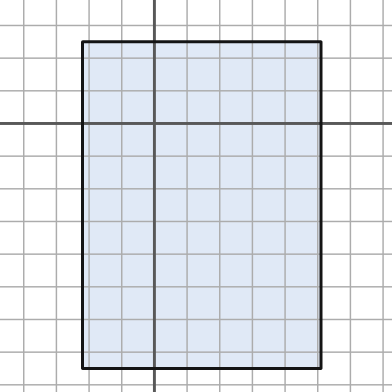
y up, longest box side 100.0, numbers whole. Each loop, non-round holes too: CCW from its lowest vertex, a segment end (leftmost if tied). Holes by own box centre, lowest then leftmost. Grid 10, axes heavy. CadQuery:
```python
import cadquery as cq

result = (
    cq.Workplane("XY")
    .moveTo(-22.0, -75.0)
    .lineTo(51.0, -75.0)
    .lineTo(51.0, 25.0)
    .lineTo(-22.0, 25.0)
    .close()
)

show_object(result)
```